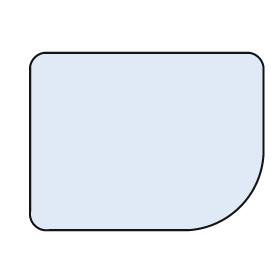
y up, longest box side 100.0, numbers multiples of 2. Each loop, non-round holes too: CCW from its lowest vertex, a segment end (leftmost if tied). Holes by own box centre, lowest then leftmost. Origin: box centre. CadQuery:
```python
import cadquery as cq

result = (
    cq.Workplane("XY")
    .moveTo(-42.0, -38.0)
    .lineTo(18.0, -38.0)
    .threePointArc((40.0, -28.0), (50.0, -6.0))
    .lineTo(50.0, 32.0)
    .threePointArc((48.0, 36.0), (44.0, 38.0))
    .lineTo(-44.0, 38.0)
    .threePointArc((-48.0, 36.0), (-50.0, 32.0))
    .lineTo(-50.0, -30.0)
    .threePointArc((-48.0, -36.0), (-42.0, -38.0))
    .close()
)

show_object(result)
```